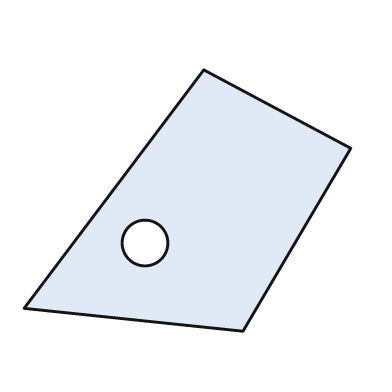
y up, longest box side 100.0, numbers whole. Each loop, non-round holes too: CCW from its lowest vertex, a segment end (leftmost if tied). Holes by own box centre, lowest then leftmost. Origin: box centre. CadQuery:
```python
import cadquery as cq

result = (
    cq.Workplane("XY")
    .moveTo(17.0, -40.0)
    .lineTo(50.0, 16.0)
    .lineTo(5.0, 40.0)
    .lineTo(-50.0, -33.0)
    .close()
    .moveTo(-13.0, -13.0)
    .circle(7.0)
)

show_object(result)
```